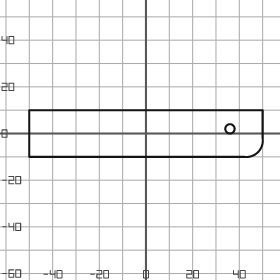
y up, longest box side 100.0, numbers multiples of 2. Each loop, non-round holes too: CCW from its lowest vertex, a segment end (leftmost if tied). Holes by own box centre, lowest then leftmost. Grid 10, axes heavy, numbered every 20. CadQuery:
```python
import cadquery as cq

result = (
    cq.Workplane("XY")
    .moveTo(-50.0, -10.0)
    .lineTo(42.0, -10.0)
    .threePointArc((48.0, -8.0), (50.0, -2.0))
    .lineTo(50.0, 10.0)
    .lineTo(-50.0, 10.0)
    .close()
    .moveTo(36.0, 2.0)
    .circle(2.0)
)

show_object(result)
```